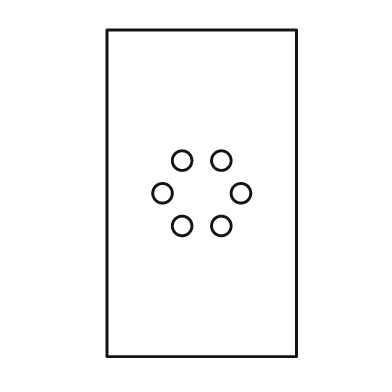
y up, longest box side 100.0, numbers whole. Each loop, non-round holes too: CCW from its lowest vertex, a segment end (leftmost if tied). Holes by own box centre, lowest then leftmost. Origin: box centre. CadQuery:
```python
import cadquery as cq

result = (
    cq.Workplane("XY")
    .moveTo(-29.0, -50.0)
    .lineTo(29.0, -50.0)
    .lineTo(29.0, 50.0)
    .lineTo(-29.0, 50.0)
    .close()
    .moveTo(-6.0, -10.0)
    .circle(3.0)
    .moveTo(6.0, -10.0)
    .circle(3.0)
    .moveTo(-12.0, 0.0)
    .circle(3.0)
    .moveTo(12.0, 0.0)
    .circle(3.0)
    .moveTo(-6.0, 10.0)
    .circle(3.0)
    .moveTo(6.0, 10.0)
    .circle(3.0)
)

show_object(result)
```